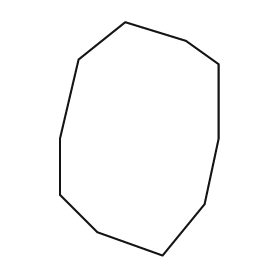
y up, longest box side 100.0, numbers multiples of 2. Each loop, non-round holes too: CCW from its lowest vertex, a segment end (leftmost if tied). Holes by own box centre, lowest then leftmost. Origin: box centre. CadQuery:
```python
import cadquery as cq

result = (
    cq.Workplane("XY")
    .moveTo(10.0, -50.0)
    .lineTo(28.0, -28.0)
    .lineTo(34.0, 0.0)
    .lineTo(34.0, 32.0)
    .lineTo(20.0, 42.0)
    .lineTo(-6.0, 50.0)
    .lineTo(-26.0, 34.0)
    .lineTo(-34.0, 0.0)
    .lineTo(-34.0, -24.0)
    .lineTo(-18.0, -40.0)
    .close()
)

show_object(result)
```